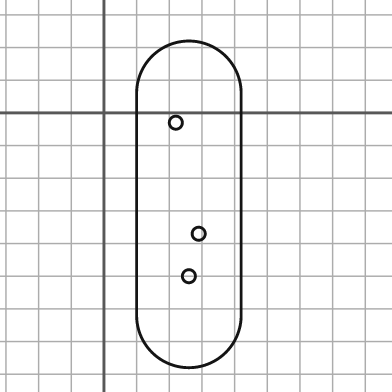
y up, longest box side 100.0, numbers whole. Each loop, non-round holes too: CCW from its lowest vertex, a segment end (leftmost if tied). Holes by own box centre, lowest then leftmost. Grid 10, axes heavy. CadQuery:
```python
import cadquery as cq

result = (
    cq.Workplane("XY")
    .moveTo(10.0, -62.0)
    .threePointArc((26.0, -78.0), (42.0, -62.0))
    .lineTo(42.0, 6.0)
    .threePointArc((26.0, 22.0), (10.0, 6.0))
    .close()
    .moveTo(26.0, -50.0)
    .circle(2.0)
    .moveTo(29.0, -37.0)
    .circle(2.0)
    .moveTo(22.0, -3.0)
    .circle(2.0)
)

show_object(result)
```